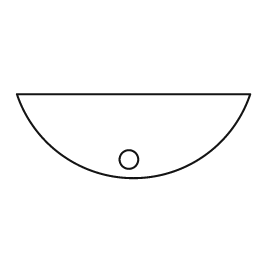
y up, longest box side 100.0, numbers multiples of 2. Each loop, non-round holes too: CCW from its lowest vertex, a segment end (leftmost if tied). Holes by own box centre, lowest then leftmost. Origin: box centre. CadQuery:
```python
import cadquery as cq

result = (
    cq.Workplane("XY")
    .moveTo(-50.0, 18.0)
    .threePointArc((0.0, -18.0), (50.0, 18.0))
    .close()
    .moveTo(-2.0, -10.0)
    .circle(4.0)
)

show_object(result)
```